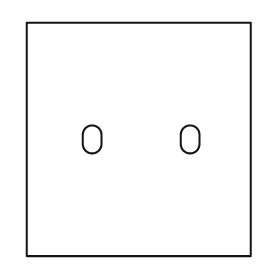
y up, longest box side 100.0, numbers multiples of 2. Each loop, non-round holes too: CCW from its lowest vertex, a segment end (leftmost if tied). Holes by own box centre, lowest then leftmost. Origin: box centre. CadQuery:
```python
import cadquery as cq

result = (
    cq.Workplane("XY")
    .moveTo(-48.0, -50.0)
    .lineTo(48.0, -50.0)
    .lineTo(48.0, 50.0)
    .lineTo(-48.0, 50.0)
    .close()
    .moveTo(-24.0, -2.0)
    .threePointArc((-20.0, -6.0), (-16.0, -2.0))
    .lineTo(-16.0, 2.0)
    .threePointArc((-20.0, 6.0), (-24.0, 2.0))
    .close()
    .moveTo(18.0, -2.0)
    .threePointArc((22.0, -6.0), (26.0, -2.0))
    .lineTo(26.0, 2.0)
    .threePointArc((22.0, 6.0), (18.0, 2.0))
    .close()
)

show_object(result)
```